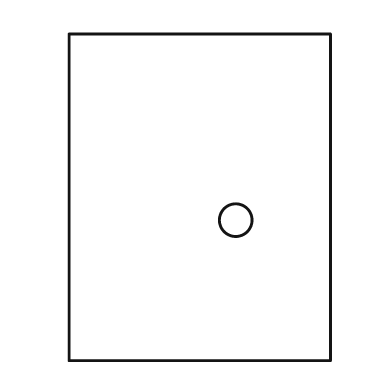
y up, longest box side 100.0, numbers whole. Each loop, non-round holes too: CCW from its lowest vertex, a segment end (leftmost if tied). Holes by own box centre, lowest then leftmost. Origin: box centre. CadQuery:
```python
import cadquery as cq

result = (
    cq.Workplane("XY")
    .moveTo(-40.0, -50.0)
    .lineTo(40.0, -50.0)
    .lineTo(40.0, 50.0)
    .lineTo(-40.0, 50.0)
    .close()
    .moveTo(11.0, -7.0)
    .circle(5.0)
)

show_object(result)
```